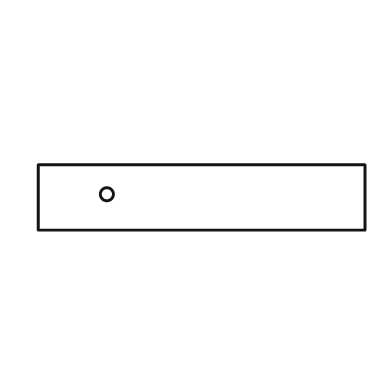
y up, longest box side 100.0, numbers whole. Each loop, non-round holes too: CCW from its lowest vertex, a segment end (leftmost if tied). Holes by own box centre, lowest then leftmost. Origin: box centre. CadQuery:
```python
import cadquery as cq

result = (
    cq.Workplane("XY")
    .moveTo(-50.0, -10.0)
    .lineTo(50.0, -10.0)
    .lineTo(50.0, 10.0)
    .lineTo(-50.0, 10.0)
    .close()
    .moveTo(-29.0, 1.0)
    .circle(2.0)
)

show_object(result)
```